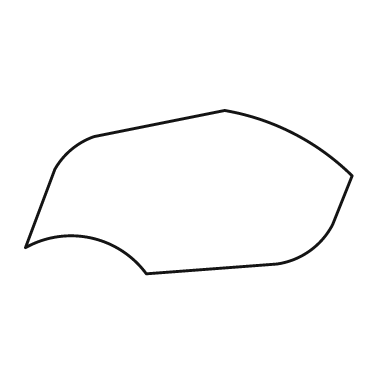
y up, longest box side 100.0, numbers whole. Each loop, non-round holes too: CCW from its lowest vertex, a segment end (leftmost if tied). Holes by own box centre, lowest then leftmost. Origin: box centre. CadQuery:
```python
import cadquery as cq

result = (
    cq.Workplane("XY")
    .moveTo(-13.0, -25.0)
    .lineTo(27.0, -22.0)
    .threePointArc((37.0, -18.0), (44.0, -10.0))
    .lineTo(50.0, 5.0)
    .threePointArc((32.0, 18.0), (11.0, 25.0))
    .lineTo(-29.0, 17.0)
    .threePointArc((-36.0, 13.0), (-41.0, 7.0))
    .lineTo(-50.0, -17.0)
    .threePointArc((-30.0, -14.0), (-13.0, -25.0))
    .close()
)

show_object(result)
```